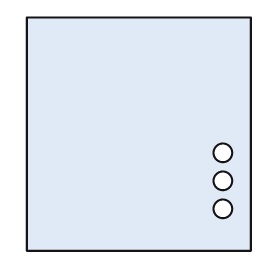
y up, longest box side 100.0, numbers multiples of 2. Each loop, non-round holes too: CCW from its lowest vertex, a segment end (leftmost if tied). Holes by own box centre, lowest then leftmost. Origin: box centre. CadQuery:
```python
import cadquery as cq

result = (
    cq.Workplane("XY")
    .moveTo(-48.0, -50.0)
    .lineTo(48.0, -50.0)
    .lineTo(48.0, 50.0)
    .lineTo(-48.0, 50.0)
    .close()
    .moveTo(36.0, -32.0)
    .circle(4.0)
    .moveTo(36.0, -20.0)
    .circle(4.0)
    .moveTo(36.0, -8.0)
    .circle(4.0)
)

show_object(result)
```